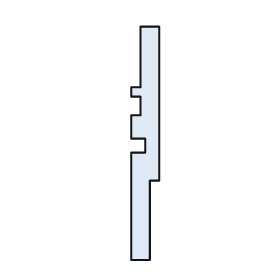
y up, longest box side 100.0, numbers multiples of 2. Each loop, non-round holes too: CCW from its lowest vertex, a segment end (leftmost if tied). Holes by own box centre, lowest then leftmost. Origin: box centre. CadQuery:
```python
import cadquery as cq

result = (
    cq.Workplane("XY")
    .moveTo(-6.0, -50.0)
    .lineTo(2.0, -50.0)
    .lineTo(2.0, -16.0)
    .lineTo(6.0, -16.0)
    .lineTo(6.0, 50.0)
    .lineTo(-2.0, 50.0)
    .lineTo(-2.0, 24.0)
    .lineTo(-6.0, 24.0)
    .lineTo(-6.0, 20.0)
    .lineTo(-2.0, 20.0)
    .lineTo(-2.0, 12.0)
    .lineTo(-6.0, 12.0)
    .lineTo(-6.0, 2.0)
    .lineTo(0.0, 2.0)
    .lineTo(0.0, -4.0)
    .lineTo(-6.0, -4.0)
    .close()
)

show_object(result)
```